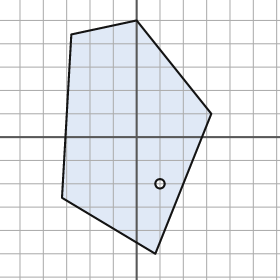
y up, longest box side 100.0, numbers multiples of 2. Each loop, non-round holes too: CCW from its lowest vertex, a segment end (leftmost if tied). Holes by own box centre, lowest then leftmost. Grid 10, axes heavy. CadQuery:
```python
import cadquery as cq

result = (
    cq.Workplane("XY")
    .moveTo(8.0, -50.0)
    .lineTo(32.0, 10.0)
    .lineTo(0.0, 50.0)
    .lineTo(-28.0, 44.0)
    .lineTo(-32.0, -26.0)
    .close()
    .moveTo(10.0, -20.0)
    .circle(2.0)
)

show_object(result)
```